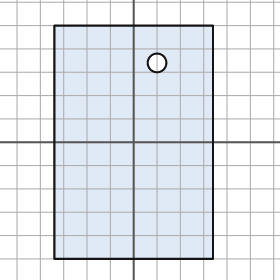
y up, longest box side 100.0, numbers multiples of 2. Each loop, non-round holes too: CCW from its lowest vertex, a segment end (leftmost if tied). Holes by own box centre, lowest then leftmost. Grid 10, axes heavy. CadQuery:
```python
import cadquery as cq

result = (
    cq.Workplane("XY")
    .moveTo(-34.0, -50.0)
    .lineTo(34.0, -50.0)
    .lineTo(34.0, 50.0)
    .lineTo(-34.0, 50.0)
    .close()
    .moveTo(10.0, 34.0)
    .circle(4.0)
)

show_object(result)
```